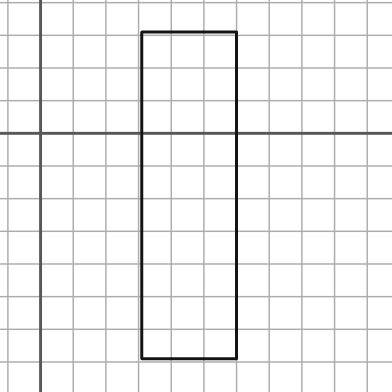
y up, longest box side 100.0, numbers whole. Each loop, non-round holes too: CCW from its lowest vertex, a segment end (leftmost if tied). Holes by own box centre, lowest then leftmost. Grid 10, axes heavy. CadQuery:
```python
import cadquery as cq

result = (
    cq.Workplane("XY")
    .moveTo(31.0, -69.0)
    .lineTo(60.0, -69.0)
    .lineTo(60.0, 31.0)
    .lineTo(31.0, 31.0)
    .close()
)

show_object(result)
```